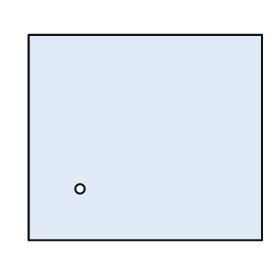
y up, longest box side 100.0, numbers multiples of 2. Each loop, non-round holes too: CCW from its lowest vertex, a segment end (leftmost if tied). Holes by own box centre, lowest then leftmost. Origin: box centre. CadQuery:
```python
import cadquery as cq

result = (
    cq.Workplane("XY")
    .moveTo(-50.0, -44.0)
    .lineTo(50.0, -44.0)
    .lineTo(50.0, 44.0)
    .lineTo(-50.0, 44.0)
    .close()
    .moveTo(-28.0, -22.0)
    .circle(2.0)
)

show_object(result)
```